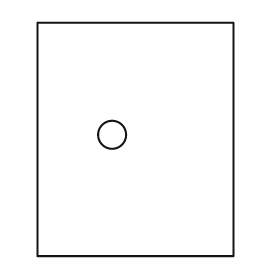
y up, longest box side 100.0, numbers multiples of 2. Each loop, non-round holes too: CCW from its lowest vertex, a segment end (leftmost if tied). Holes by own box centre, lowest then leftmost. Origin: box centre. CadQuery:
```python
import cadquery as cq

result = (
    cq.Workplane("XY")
    .moveTo(-42.0, -50.0)
    .lineTo(42.0, -50.0)
    .lineTo(42.0, 50.0)
    .lineTo(-42.0, 50.0)
    .close()
    .moveTo(-10.0, 2.0)
    .circle(6.0)
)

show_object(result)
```